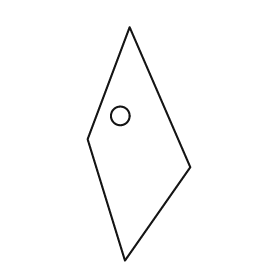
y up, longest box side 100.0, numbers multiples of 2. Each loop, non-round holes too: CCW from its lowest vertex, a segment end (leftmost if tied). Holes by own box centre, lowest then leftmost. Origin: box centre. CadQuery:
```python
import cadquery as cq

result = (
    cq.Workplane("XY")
    .moveTo(-6.0, -50.0)
    .lineTo(22.0, -10.0)
    .lineTo(-4.0, 50.0)
    .lineTo(-22.0, 2.0)
    .close()
    .moveTo(-8.0, 12.0)
    .circle(4.0)
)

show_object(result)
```